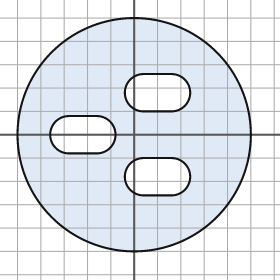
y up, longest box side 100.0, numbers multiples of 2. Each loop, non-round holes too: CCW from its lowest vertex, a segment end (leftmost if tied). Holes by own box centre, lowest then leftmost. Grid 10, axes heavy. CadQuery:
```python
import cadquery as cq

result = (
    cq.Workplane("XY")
    .moveTo(0.0, 0.0)
    .circle(50.0)
    .moveTo(4.0, -26.0)
    .lineTo(16.0, -26.0)
    .threePointArc((24.0, -18.0), (16.0, -10.0))
    .lineTo(4.0, -10.0)
    .threePointArc((-4.0, -18.0), (4.0, -26.0))
    .close()
    .moveTo(-28.0, -8.0)
    .lineTo(-16.0, -8.0)
    .threePointArc((-8.0, 0.0), (-16.0, 8.0))
    .lineTo(-28.0, 8.0)
    .threePointArc((-36.0, 0.0), (-28.0, -8.0))
    .close()
    .moveTo(4.0, 10.0)
    .lineTo(16.0, 10.0)
    .threePointArc((24.0, 18.0), (16.0, 26.0))
    .lineTo(4.0, 26.0)
    .threePointArc((-4.0, 18.0), (4.0, 10.0))
    .close()
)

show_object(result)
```